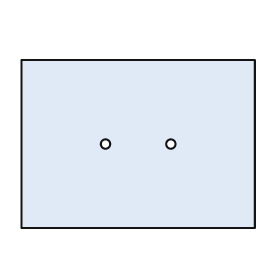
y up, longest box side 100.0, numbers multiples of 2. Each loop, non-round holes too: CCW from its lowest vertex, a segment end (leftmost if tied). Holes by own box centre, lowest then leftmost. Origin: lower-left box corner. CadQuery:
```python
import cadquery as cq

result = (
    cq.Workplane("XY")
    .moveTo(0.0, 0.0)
    .lineTo(100.0, 0.0)
    .lineTo(100.0, 72.0)
    .lineTo(0.0, 72.0)
    .close()
    .moveTo(36.0, 36.0)
    .circle(2.0)
    .moveTo(64.0, 36.0)
    .circle(2.0)
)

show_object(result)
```